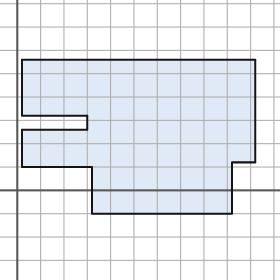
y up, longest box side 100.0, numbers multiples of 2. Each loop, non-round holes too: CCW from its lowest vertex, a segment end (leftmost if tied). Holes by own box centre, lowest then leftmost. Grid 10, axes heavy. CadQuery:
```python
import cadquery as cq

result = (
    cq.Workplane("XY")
    .moveTo(32.0, -10.0)
    .lineTo(92.0, -10.0)
    .lineTo(92.0, 12.0)
    .lineTo(102.0, 12.0)
    .lineTo(102.0, 56.0)
    .lineTo(2.0, 56.0)
    .lineTo(2.0, 32.0)
    .lineTo(30.0, 32.0)
    .lineTo(30.0, 26.0)
    .lineTo(2.0, 26.0)
    .lineTo(2.0, 10.0)
    .lineTo(32.0, 10.0)
    .close()
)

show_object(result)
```